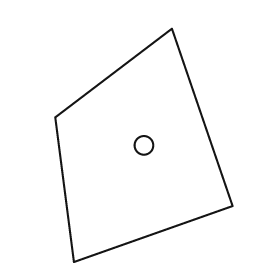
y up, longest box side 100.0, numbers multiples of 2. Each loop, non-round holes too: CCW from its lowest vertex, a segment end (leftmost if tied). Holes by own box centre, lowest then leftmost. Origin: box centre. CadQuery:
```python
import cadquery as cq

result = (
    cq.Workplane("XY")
    .moveTo(-30.0, -50.0)
    .lineTo(38.0, -26.0)
    .lineTo(12.0, 50.0)
    .lineTo(-38.0, 12.0)
    .close()
    .moveTo(0.0, 0.0)
    .circle(4.0)
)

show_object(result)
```